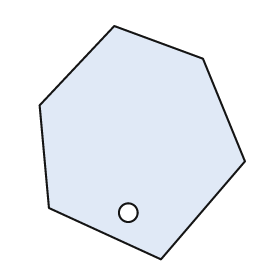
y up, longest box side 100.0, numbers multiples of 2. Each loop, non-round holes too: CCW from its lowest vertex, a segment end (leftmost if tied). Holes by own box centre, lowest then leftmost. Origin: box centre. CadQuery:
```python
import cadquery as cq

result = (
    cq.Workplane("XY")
    .moveTo(8.0, -50.0)
    .lineTo(44.0, -8.0)
    .lineTo(26.0, 36.0)
    .lineTo(-12.0, 50.0)
    .lineTo(-44.0, 16.0)
    .lineTo(-40.0, -28.0)
    .close()
    .moveTo(-6.0, -30.0)
    .circle(4.0)
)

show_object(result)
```